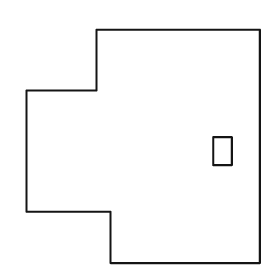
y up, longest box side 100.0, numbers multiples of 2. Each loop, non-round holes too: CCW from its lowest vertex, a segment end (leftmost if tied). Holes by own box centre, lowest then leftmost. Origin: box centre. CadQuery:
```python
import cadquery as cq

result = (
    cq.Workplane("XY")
    .moveTo(-14.0, -50.0)
    .lineTo(50.0, -50.0)
    .lineTo(50.0, 50.0)
    .lineTo(-20.0, 50.0)
    .lineTo(-20.0, 24.0)
    .lineTo(-50.0, 24.0)
    .lineTo(-50.0, -28.0)
    .lineTo(-14.0, -28.0)
    .close()
    .moveTo(30.0, -8.0)
    .lineTo(38.0, -8.0)
    .lineTo(38.0, 4.0)
    .lineTo(30.0, 4.0)
    .close()
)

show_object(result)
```